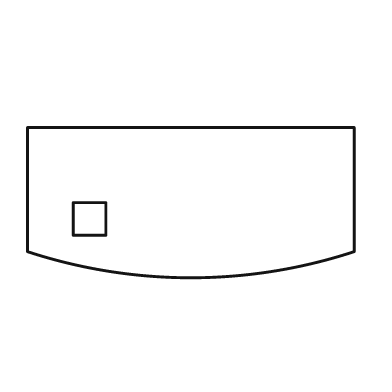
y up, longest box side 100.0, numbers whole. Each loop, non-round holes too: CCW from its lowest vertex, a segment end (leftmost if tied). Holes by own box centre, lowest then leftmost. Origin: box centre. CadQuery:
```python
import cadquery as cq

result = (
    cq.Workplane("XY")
    .moveTo(-50.0, -15.0)
    .threePointArc((0.0, -23.0), (50.0, -15.0))
    .lineTo(50.0, 23.0)
    .lineTo(-50.0, 23.0)
    .close()
    .moveTo(-36.0, -10.0)
    .lineTo(-26.0, -10.0)
    .lineTo(-26.0, 0.0)
    .lineTo(-36.0, 0.0)
    .close()
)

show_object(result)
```